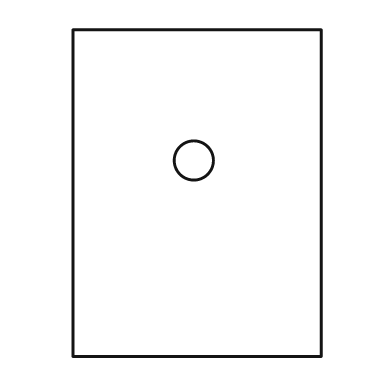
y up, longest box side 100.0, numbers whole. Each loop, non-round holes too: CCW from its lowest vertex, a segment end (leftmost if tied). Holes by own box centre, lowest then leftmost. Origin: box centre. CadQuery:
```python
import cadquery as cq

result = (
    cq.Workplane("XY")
    .moveTo(-38.0, -50.0)
    .lineTo(38.0, -50.0)
    .lineTo(38.0, 50.0)
    .lineTo(-38.0, 50.0)
    .close()
    .moveTo(-1.0, 10.0)
    .circle(6.0)
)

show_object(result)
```